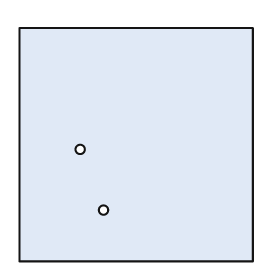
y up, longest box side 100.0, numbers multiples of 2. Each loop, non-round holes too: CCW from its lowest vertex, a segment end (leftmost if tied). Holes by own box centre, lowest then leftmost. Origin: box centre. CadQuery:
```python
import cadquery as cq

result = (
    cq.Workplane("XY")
    .moveTo(-50.0, -50.0)
    .lineTo(50.0, -50.0)
    .lineTo(50.0, 50.0)
    .lineTo(-50.0, 50.0)
    .close()
    .moveTo(-14.0, -28.0)
    .circle(2.0)
    .moveTo(-24.0, -2.0)
    .circle(2.0)
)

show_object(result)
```